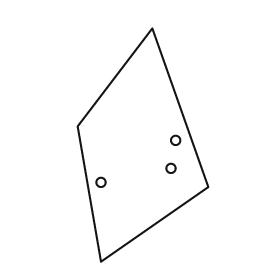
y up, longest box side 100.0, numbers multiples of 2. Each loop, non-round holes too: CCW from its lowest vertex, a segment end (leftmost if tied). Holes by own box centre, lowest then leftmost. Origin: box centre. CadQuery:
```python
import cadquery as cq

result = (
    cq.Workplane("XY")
    .moveTo(-18.0, -50.0)
    .lineTo(28.0, -18.0)
    .lineTo(4.0, 50.0)
    .lineTo(-28.0, 8.0)
    .close()
    .moveTo(-18.0, -16.0)
    .circle(2.0)
    .moveTo(12.0, -10.0)
    .circle(2.0)
    .moveTo(14.0, 2.0)
    .circle(2.0)
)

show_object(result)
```